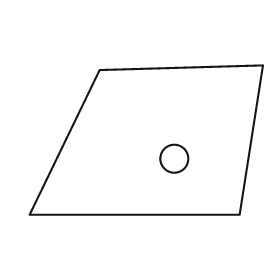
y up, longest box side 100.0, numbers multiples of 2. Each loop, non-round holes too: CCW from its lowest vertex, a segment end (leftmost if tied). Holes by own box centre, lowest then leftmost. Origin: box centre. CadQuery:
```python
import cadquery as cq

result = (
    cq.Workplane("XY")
    .moveTo(-50.0, -32.0)
    .lineTo(40.0, -32.0)
    .lineTo(50.0, 32.0)
    .lineTo(-20.0, 30.0)
    .close()
    .moveTo(12.0, -8.0)
    .circle(6.0)
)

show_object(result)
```